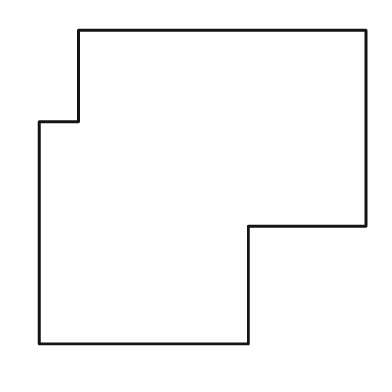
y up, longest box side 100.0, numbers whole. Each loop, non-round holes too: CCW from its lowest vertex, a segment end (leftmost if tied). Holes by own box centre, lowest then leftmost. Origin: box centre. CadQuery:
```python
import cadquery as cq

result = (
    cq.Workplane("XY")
    .moveTo(-50.0, -48.0)
    .lineTo(14.0, -48.0)
    .lineTo(14.0, -12.0)
    .lineTo(50.0, -12.0)
    .lineTo(50.0, 48.0)
    .lineTo(-38.0, 48.0)
    .lineTo(-38.0, 20.0)
    .lineTo(-50.0, 20.0)
    .close()
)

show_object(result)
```